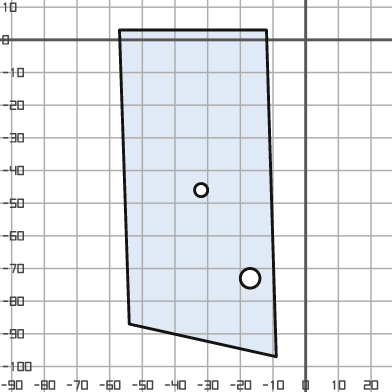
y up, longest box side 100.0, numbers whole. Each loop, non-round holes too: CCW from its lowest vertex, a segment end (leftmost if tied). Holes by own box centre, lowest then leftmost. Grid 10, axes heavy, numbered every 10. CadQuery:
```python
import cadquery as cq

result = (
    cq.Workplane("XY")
    .moveTo(-9.0, -97.0)
    .lineTo(-12.0, 3.0)
    .lineTo(-57.0, 3.0)
    .lineTo(-54.0, -87.0)
    .close()
    .moveTo(-17.0, -73.0)
    .circle(3.0)
    .moveTo(-32.0, -46.0)
    .circle(2.0)
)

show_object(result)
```